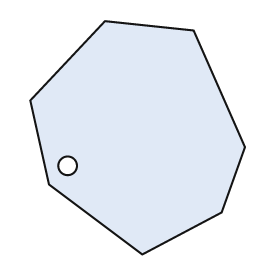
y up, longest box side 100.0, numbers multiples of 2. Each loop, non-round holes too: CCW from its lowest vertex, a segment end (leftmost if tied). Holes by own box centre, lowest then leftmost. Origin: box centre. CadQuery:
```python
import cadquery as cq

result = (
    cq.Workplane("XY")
    .moveTo(2.0, -50.0)
    .lineTo(36.0, -32.0)
    .lineTo(46.0, -4.0)
    .lineTo(24.0, 46.0)
    .lineTo(-14.0, 50.0)
    .lineTo(-46.0, 16.0)
    .lineTo(-38.0, -20.0)
    .close()
    .moveTo(-30.0, -12.0)
    .circle(4.0)
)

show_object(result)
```